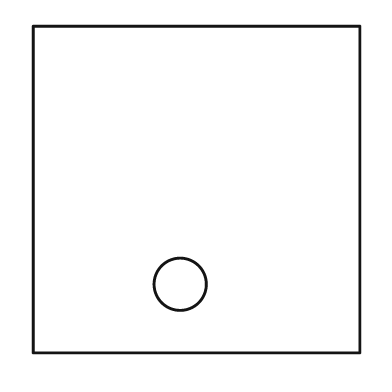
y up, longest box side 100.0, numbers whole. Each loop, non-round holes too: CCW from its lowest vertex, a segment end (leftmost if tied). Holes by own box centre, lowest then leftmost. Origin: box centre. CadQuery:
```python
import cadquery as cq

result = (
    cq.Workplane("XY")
    .moveTo(-50.0, -50.0)
    .lineTo(50.0, -50.0)
    .lineTo(50.0, 50.0)
    .lineTo(-50.0, 50.0)
    .close()
    .moveTo(-5.0, -29.0)
    .circle(8.0)
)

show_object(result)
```